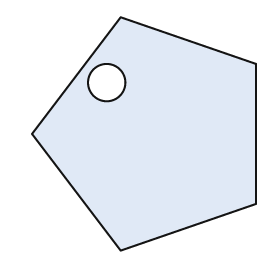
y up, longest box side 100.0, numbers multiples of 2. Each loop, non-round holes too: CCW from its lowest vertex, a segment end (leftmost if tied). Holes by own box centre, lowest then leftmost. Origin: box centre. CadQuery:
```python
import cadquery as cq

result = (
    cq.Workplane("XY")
    .moveTo(-10.0, -50.0)
    .lineTo(48.0, -30.0)
    .lineTo(48.0, 30.0)
    .lineTo(-10.0, 50.0)
    .lineTo(-48.0, 0.0)
    .close()
    .moveTo(-16.0, 22.0)
    .circle(8.0)
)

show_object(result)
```